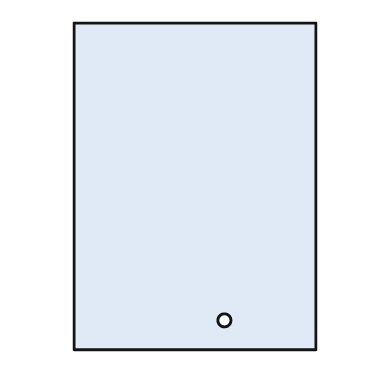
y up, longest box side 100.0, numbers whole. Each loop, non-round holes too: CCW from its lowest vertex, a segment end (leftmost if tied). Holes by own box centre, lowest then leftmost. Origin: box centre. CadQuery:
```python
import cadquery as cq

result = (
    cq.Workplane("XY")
    .moveTo(-37.0, -50.0)
    .lineTo(37.0, -50.0)
    .lineTo(37.0, 50.0)
    .lineTo(-37.0, 50.0)
    .close()
    .moveTo(9.0, -41.0)
    .circle(2.0)
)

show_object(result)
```